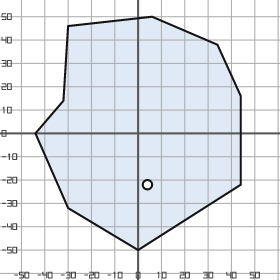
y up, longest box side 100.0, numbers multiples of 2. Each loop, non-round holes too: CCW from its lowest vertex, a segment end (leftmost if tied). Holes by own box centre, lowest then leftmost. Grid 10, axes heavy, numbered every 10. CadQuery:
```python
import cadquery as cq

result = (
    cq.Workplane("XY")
    .moveTo(0.0, -50.0)
    .lineTo(44.0, -22.0)
    .lineTo(44.0, 16.0)
    .lineTo(34.0, 38.0)
    .lineTo(6.0, 50.0)
    .lineTo(-30.0, 46.0)
    .lineTo(-32.0, 14.0)
    .lineTo(-44.0, 0.0)
    .lineTo(-30.0, -32.0)
    .close()
    .moveTo(4.0, -22.0)
    .circle(2.0)
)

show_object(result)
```